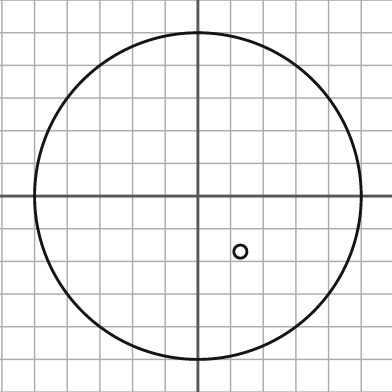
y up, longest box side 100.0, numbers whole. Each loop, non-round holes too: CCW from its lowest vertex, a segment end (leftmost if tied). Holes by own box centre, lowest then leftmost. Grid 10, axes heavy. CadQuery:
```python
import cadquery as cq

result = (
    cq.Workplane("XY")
    .moveTo(0.0, 0.0)
    .circle(50.0)
    .moveTo(13.0, -17.0)
    .circle(2.0)
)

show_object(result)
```